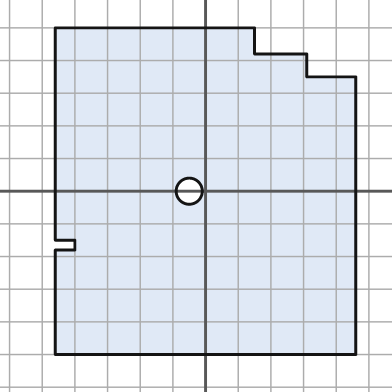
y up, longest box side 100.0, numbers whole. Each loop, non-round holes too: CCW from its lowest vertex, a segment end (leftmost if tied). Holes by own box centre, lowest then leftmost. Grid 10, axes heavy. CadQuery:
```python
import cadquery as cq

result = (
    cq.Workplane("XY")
    .moveTo(-46.0, -50.0)
    .lineTo(46.0, -50.0)
    .lineTo(46.0, 35.0)
    .lineTo(31.0, 35.0)
    .lineTo(31.0, 42.0)
    .lineTo(15.0, 42.0)
    .lineTo(15.0, 50.0)
    .lineTo(-46.0, 50.0)
    .lineTo(-46.0, -15.0)
    .lineTo(-40.0, -15.0)
    .lineTo(-40.0, -18.0)
    .lineTo(-46.0, -18.0)
    .close()
    .moveTo(-5.0, 0.0)
    .circle(4.0)
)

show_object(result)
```